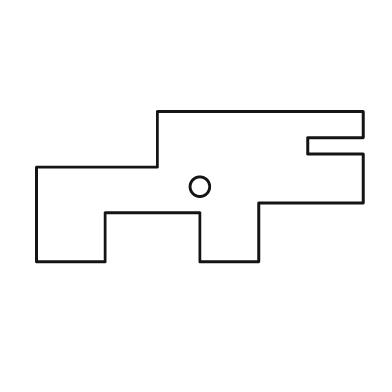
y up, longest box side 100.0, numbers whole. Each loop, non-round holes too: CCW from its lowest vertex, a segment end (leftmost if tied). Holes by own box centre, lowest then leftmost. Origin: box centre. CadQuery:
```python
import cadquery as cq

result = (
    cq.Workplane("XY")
    .moveTo(-50.0, -23.0)
    .lineTo(-29.0, -23.0)
    .lineTo(-29.0, -8.0)
    .lineTo(0.0, -8.0)
    .lineTo(0.0, -23.0)
    .lineTo(18.0, -23.0)
    .lineTo(18.0, -5.0)
    .lineTo(50.0, -5.0)
    .lineTo(50.0, 10.0)
    .lineTo(33.0, 10.0)
    .lineTo(33.0, 15.0)
    .lineTo(50.0, 15.0)
    .lineTo(50.0, 23.0)
    .lineTo(-13.0, 23.0)
    .lineTo(-13.0, 6.0)
    .lineTo(-50.0, 6.0)
    .close()
    .moveTo(0.0, 0.0)
    .circle(3.0)
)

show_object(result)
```